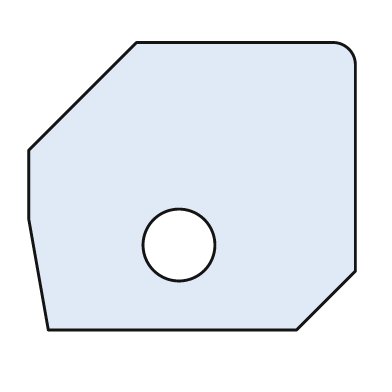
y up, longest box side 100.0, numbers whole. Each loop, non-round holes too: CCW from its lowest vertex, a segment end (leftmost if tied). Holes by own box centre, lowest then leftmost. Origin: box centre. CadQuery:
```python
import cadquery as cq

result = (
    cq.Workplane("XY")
    .moveTo(-44.0, -44.0)
    .lineTo(32.0, -44.0)
    .lineTo(50.0, -26.0)
    .lineTo(50.0, 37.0)
    .threePointArc((48.0, 42.0), (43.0, 44.0))
    .lineTo(-17.0, 44.0)
    .lineTo(-50.0, 11.0)
    .lineTo(-50.0, -10.0)
    .close()
    .moveTo(-4.0, -18.0)
    .circle(11.0)
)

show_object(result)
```